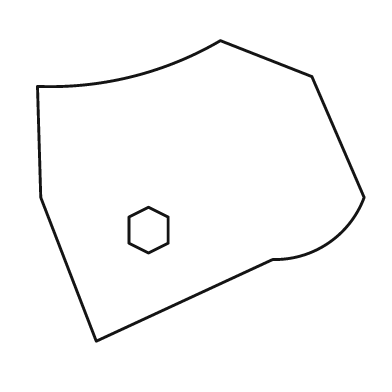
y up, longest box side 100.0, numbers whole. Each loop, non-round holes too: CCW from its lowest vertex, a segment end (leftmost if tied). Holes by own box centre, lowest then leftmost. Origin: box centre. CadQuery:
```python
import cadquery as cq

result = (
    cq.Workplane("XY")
    .moveTo(-32.0, -46.0)
    .lineTo(22.0, -21.0)
    .threePointArc((39.0, -16.0), (50.0, -2.0))
    .lineTo(34.0, 35.0)
    .lineTo(6.0, 46.0)
    .threePointArc((-21.0, 35.0), (-50.0, 32.0))
    .lineTo(-49.0, -2.0)
    .close()
    .moveTo(-16.0, -19.0)
    .lineTo(-10.0, -16.0)
    .lineTo(-10.0, -8.0)
    .lineTo(-16.0, -5.0)
    .lineTo(-22.0, -8.0)
    .lineTo(-22.0, -16.0)
    .close()
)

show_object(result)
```